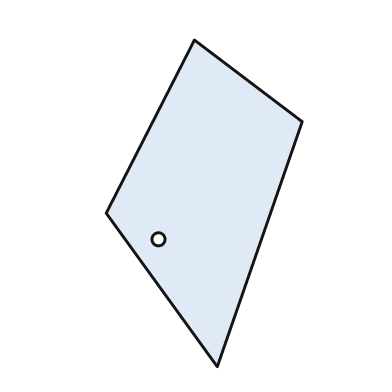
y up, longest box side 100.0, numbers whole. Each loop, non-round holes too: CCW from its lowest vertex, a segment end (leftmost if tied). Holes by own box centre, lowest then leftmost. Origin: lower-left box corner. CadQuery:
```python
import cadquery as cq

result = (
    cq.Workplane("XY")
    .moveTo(34.0, 0.0)
    .lineTo(60.0, 75.0)
    .lineTo(27.0, 100.0)
    .lineTo(0.0, 47.0)
    .close()
    .moveTo(16.0, 39.0)
    .circle(2.0)
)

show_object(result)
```